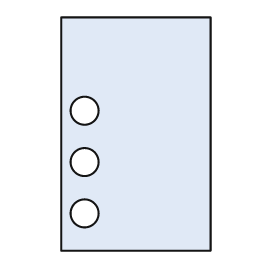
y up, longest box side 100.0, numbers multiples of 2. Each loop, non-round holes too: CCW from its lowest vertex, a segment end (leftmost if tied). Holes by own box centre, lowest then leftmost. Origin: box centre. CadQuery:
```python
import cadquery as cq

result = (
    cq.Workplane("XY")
    .moveTo(-32.0, -50.0)
    .lineTo(32.0, -50.0)
    .lineTo(32.0, 50.0)
    .lineTo(-32.0, 50.0)
    .close()
    .moveTo(-22.0, -34.0)
    .circle(6.0)
    .moveTo(-22.0, -12.0)
    .circle(6.0)
    .moveTo(-22.0, 10.0)
    .circle(6.0)
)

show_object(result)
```